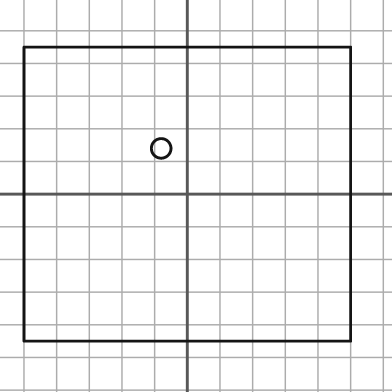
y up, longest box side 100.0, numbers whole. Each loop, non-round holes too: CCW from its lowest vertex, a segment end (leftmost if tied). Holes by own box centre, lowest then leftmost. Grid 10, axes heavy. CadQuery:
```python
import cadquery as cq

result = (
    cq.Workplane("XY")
    .moveTo(-50.0, -45.0)
    .lineTo(50.0, -45.0)
    .lineTo(50.0, 45.0)
    .lineTo(-50.0, 45.0)
    .close()
    .moveTo(-8.0, 14.0)
    .circle(3.0)
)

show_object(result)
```